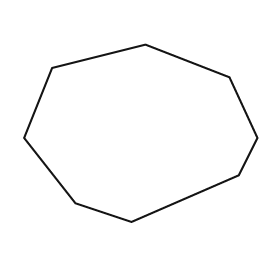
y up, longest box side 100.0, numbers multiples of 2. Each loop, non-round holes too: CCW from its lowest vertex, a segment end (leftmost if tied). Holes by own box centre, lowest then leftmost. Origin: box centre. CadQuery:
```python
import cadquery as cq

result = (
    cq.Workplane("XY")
    .moveTo(-4.0, -38.0)
    .lineTo(42.0, -18.0)
    .lineTo(50.0, -2.0)
    .lineTo(38.0, 24.0)
    .lineTo(2.0, 38.0)
    .lineTo(-38.0, 28.0)
    .lineTo(-50.0, -2.0)
    .lineTo(-28.0, -30.0)
    .close()
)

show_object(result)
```